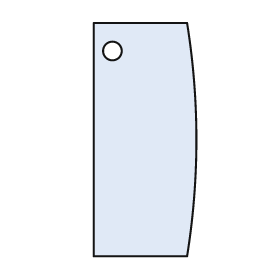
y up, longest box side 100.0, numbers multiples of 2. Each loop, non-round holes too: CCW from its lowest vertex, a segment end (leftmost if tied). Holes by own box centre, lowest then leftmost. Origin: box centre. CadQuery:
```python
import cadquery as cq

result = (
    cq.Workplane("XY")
    .moveTo(-22.0, -50.0)
    .lineTo(18.0, -50.0)
    .threePointArc((22.0, 0.0), (18.0, 50.0))
    .lineTo(-22.0, 50.0)
    .close()
    .moveTo(-14.0, 38.0)
    .circle(4.0)
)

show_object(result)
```